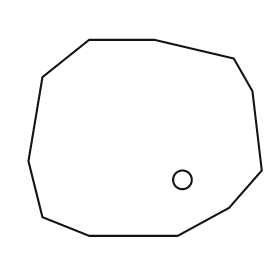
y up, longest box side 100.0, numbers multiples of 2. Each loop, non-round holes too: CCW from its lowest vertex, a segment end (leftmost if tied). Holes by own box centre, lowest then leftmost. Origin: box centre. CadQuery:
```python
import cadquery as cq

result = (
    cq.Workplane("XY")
    .moveTo(-24.0, -42.0)
    .lineTo(14.0, -42.0)
    .lineTo(36.0, -30.0)
    .lineTo(50.0, -14.0)
    .lineTo(46.0, 20.0)
    .lineTo(38.0, 34.0)
    .lineTo(4.0, 42.0)
    .lineTo(-24.0, 42.0)
    .lineTo(-44.0, 26.0)
    .lineTo(-50.0, -10.0)
    .lineTo(-44.0, -34.0)
    .close()
    .moveTo(16.0, -18.0)
    .circle(4.0)
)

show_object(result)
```